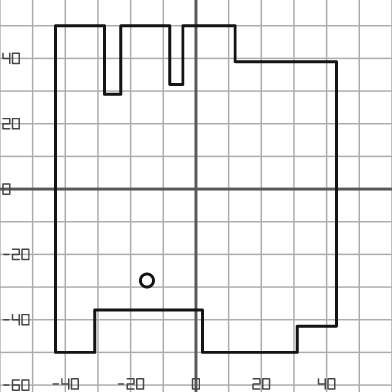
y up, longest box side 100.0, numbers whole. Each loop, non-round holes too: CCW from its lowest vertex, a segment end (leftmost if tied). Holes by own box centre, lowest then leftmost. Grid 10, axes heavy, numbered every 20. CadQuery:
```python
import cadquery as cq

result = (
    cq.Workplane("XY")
    .moveTo(-43.0, -50.0)
    .lineTo(-31.0, -50.0)
    .lineTo(-31.0, -37.0)
    .lineTo(2.0, -37.0)
    .lineTo(2.0, -50.0)
    .lineTo(31.0, -50.0)
    .lineTo(31.0, -42.0)
    .lineTo(43.0, -42.0)
    .lineTo(43.0, 39.0)
    .lineTo(12.0, 39.0)
    .lineTo(12.0, 50.0)
    .lineTo(-4.0, 50.0)
    .lineTo(-4.0, 32.0)
    .lineTo(-8.0, 32.0)
    .lineTo(-8.0, 50.0)
    .lineTo(-23.0, 50.0)
    .lineTo(-23.0, 29.0)
    .lineTo(-28.0, 29.0)
    .lineTo(-28.0, 50.0)
    .lineTo(-43.0, 50.0)
    .close()
    .moveTo(-15.0, -28.0)
    .circle(2.0)
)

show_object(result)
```